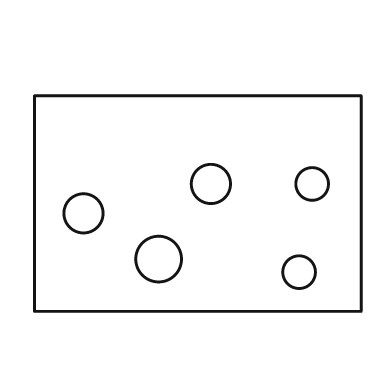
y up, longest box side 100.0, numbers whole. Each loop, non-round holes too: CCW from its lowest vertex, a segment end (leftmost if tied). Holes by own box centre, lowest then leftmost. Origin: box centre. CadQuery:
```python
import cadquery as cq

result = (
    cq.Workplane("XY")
    .moveTo(-50.0, -33.0)
    .lineTo(50.0, -33.0)
    .lineTo(50.0, 33.0)
    .lineTo(-50.0, 33.0)
    .close()
    .moveTo(31.0, -21.0)
    .circle(5.0)
    .moveTo(-12.0, -17.0)
    .circle(7.0)
    .moveTo(-35.0, -3.0)
    .circle(6.0)
    .moveTo(4.0, 6.0)
    .circle(6.0)
    .moveTo(35.0, 6.0)
    .circle(5.0)
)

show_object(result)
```